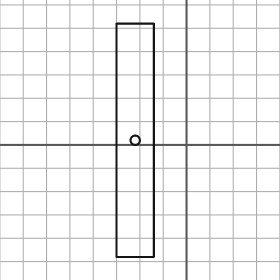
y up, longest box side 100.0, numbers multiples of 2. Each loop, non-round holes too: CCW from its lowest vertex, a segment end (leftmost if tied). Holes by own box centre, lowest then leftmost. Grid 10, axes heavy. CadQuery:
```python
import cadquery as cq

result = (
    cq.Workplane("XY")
    .moveTo(-30.0, -48.0)
    .lineTo(-14.0, -48.0)
    .lineTo(-14.0, 52.0)
    .lineTo(-30.0, 52.0)
    .close()
    .moveTo(-22.0, 2.0)
    .circle(2.0)
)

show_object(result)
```